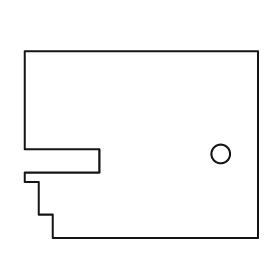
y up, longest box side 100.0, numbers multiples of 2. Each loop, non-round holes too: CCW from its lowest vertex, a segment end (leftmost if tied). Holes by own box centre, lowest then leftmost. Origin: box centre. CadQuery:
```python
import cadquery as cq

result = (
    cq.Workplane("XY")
    .moveTo(-38.0, -40.0)
    .lineTo(50.0, -40.0)
    .lineTo(50.0, 40.0)
    .lineTo(-50.0, 40.0)
    .lineTo(-50.0, -2.0)
    .lineTo(-18.0, -2.0)
    .lineTo(-18.0, -12.0)
    .lineTo(-50.0, -12.0)
    .lineTo(-50.0, -16.0)
    .lineTo(-44.0, -16.0)
    .lineTo(-44.0, -30.0)
    .lineTo(-38.0, -30.0)
    .close()
    .moveTo(34.0, -4.0)
    .circle(4.0)
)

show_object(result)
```